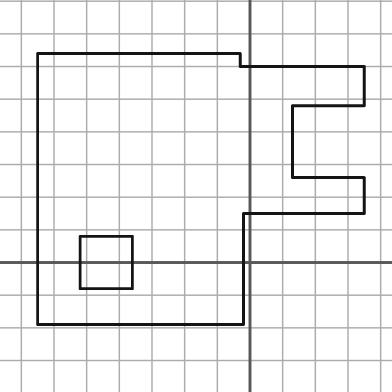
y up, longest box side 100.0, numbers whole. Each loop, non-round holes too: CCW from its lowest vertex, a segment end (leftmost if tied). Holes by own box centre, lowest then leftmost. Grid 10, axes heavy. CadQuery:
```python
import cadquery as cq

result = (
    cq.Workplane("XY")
    .moveTo(-65.0, -19.0)
    .lineTo(-2.0, -19.0)
    .lineTo(-2.0, 15.0)
    .lineTo(35.0, 15.0)
    .lineTo(35.0, 26.0)
    .lineTo(13.0, 26.0)
    .lineTo(13.0, 48.0)
    .lineTo(35.0, 48.0)
    .lineTo(35.0, 60.0)
    .lineTo(-3.0, 60.0)
    .lineTo(-3.0, 64.0)
    .lineTo(-65.0, 64.0)
    .close()
    .moveTo(-52.0, -8.0)
    .lineTo(-36.0, -8.0)
    .lineTo(-36.0, 8.0)
    .lineTo(-52.0, 8.0)
    .close()
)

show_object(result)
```